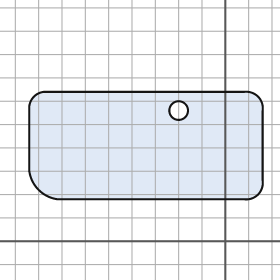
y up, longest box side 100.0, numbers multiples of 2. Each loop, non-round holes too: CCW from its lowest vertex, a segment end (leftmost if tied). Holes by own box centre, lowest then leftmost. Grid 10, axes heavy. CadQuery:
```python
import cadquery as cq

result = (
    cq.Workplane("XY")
    .moveTo(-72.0, 18.0)
    .lineTo(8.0, 18.0)
    .threePointArc((14.0, 20.0), (16.0, 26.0))
    .lineTo(16.0, 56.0)
    .threePointArc((14.0, 62.0), (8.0, 64.0))
    .lineTo(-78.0, 64.0)
    .threePointArc((-82.0, 62.0), (-84.0, 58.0))
    .lineTo(-84.0, 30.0)
    .threePointArc((-80.0, 22.0), (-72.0, 18.0))
    .close()
    .moveTo(-20.0, 56.0)
    .circle(4.0)
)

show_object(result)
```